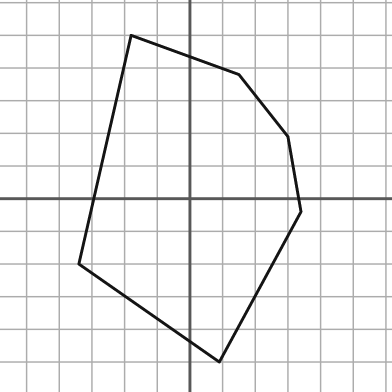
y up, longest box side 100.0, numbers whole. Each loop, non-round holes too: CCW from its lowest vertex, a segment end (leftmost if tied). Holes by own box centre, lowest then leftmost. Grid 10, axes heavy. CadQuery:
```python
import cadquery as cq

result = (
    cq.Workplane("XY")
    .moveTo(9.0, -50.0)
    .lineTo(34.0, -4.0)
    .lineTo(30.0, 19.0)
    .lineTo(15.0, 38.0)
    .lineTo(-18.0, 50.0)
    .lineTo(-34.0, -20.0)
    .close()
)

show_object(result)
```